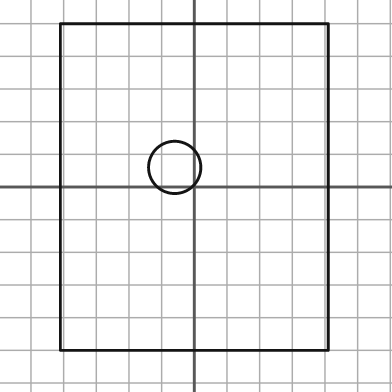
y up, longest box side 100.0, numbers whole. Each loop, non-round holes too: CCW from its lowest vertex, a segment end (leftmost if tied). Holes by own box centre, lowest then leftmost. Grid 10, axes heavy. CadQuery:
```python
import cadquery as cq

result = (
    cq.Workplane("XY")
    .moveTo(-41.0, -50.0)
    .lineTo(41.0, -50.0)
    .lineTo(41.0, 50.0)
    .lineTo(-41.0, 50.0)
    .close()
    .moveTo(-6.0, 6.0)
    .circle(8.0)
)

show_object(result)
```